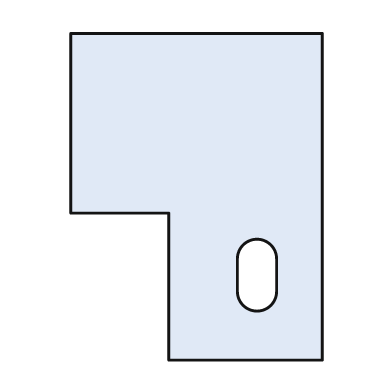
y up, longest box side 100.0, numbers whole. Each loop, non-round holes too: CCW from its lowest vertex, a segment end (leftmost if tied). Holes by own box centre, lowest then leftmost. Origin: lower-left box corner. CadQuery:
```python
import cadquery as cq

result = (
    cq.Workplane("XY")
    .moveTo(30.0, 0.0)
    .lineTo(77.0, 0.0)
    .lineTo(77.0, 100.0)
    .lineTo(0.0, 100.0)
    .lineTo(0.0, 45.0)
    .lineTo(30.0, 45.0)
    .close()
    .moveTo(51.0, 21.0)
    .threePointArc((57.0, 15.0), (63.0, 21.0))
    .lineTo(63.0, 31.0)
    .threePointArc((57.0, 37.0), (51.0, 31.0))
    .close()
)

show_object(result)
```